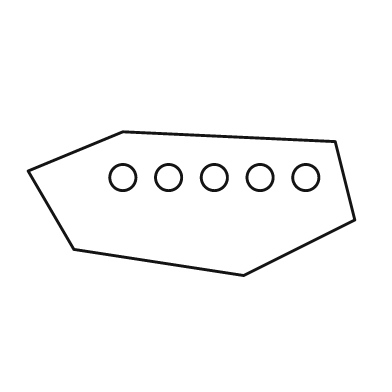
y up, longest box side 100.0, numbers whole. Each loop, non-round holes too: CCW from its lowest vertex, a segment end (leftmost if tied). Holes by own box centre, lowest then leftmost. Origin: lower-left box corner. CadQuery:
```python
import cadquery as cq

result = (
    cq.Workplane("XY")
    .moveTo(66.0, 0.0)
    .lineTo(100.0, 17.0)
    .lineTo(94.0, 41.0)
    .lineTo(29.0, 44.0)
    .lineTo(0.0, 32.0)
    .lineTo(14.0, 8.0)
    .close()
    .moveTo(29.0, 30.0)
    .circle(4.0)
    .moveTo(43.0, 30.0)
    .circle(4.0)
    .moveTo(57.0, 30.0)
    .circle(4.0)
    .moveTo(71.0, 30.0)
    .circle(4.0)
    .moveTo(85.0, 30.0)
    .circle(4.0)
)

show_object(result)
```